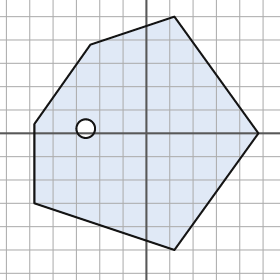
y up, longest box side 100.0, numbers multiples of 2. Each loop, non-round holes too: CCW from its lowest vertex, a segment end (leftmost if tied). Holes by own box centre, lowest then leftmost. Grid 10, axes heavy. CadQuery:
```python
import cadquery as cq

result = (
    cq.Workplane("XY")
    .moveTo(12.0, -50.0)
    .lineTo(48.0, 0.0)
    .lineTo(12.0, 50.0)
    .lineTo(-24.0, 38.0)
    .lineTo(-48.0, 4.0)
    .lineTo(-48.0, -30.0)
    .close()
    .moveTo(-26.0, 2.0)
    .circle(4.0)
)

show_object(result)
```